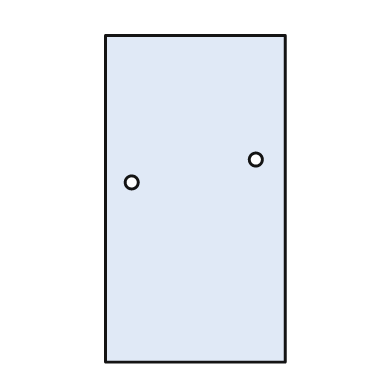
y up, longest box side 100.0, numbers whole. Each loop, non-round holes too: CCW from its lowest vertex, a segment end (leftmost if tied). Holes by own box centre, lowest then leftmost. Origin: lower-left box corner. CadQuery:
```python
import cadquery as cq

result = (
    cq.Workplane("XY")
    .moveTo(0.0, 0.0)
    .lineTo(55.0, 0.0)
    .lineTo(55.0, 100.0)
    .lineTo(0.0, 100.0)
    .close()
    .moveTo(8.0, 55.0)
    .circle(2.0)
    .moveTo(46.0, 62.0)
    .circle(2.0)
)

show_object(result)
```